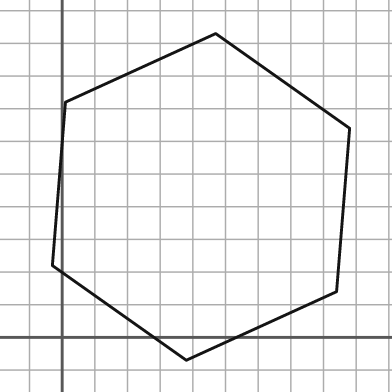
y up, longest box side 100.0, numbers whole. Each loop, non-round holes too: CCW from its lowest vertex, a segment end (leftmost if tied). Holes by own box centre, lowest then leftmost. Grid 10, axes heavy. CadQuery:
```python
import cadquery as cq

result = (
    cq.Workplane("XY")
    .moveTo(38.0, -7.0)
    .lineTo(84.0, 14.0)
    .lineTo(88.0, 64.0)
    .lineTo(47.0, 93.0)
    .lineTo(1.0, 72.0)
    .lineTo(-3.0, 22.0)
    .close()
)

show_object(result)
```